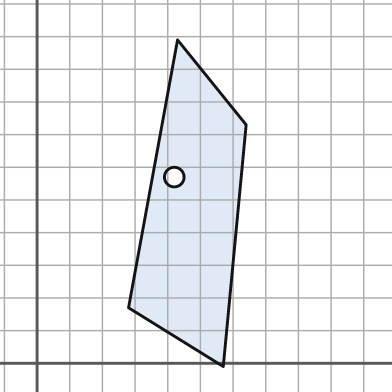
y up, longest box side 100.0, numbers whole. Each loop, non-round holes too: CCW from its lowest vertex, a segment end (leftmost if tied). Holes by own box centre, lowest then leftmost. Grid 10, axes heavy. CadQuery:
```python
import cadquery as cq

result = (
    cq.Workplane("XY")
    .moveTo(57.0, -1.0)
    .lineTo(64.0, 73.0)
    .lineTo(43.0, 99.0)
    .lineTo(28.0, 17.0)
    .close()
    .moveTo(42.0, 57.0)
    .circle(3.0)
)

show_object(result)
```